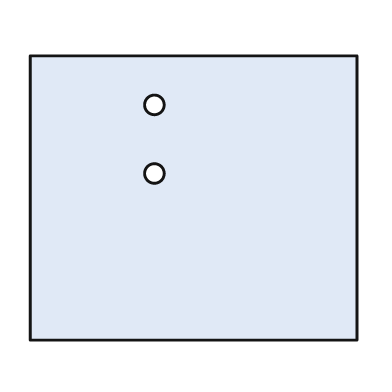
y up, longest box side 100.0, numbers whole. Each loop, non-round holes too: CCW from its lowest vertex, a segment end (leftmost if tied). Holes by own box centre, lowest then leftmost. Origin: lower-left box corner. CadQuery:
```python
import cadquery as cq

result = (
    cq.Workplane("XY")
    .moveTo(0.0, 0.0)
    .lineTo(100.0, 0.0)
    .lineTo(100.0, 87.0)
    .lineTo(0.0, 87.0)
    .close()
    .moveTo(38.0, 51.0)
    .circle(3.0)
    .moveTo(38.0, 72.0)
    .circle(3.0)
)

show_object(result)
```